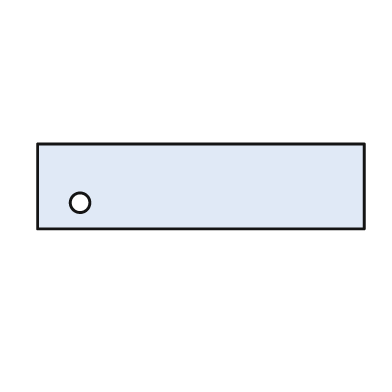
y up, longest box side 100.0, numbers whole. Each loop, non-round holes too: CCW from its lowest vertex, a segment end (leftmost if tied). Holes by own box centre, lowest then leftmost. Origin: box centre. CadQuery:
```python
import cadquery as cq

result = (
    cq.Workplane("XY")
    .moveTo(-50.0, -13.0)
    .lineTo(50.0, -13.0)
    .lineTo(50.0, 13.0)
    .lineTo(-50.0, 13.0)
    .close()
    .moveTo(-37.0, -5.0)
    .circle(3.0)
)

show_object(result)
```